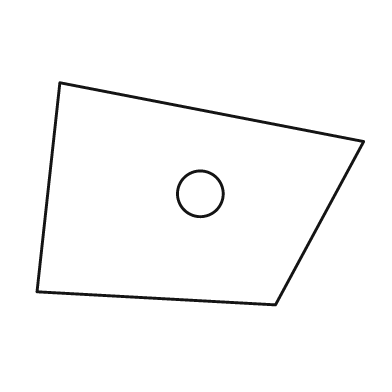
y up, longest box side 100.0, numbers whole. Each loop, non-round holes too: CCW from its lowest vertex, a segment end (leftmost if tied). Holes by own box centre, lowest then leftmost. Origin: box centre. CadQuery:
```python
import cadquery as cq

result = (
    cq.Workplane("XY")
    .moveTo(23.0, -34.0)
    .lineTo(50.0, 16.0)
    .lineTo(-43.0, 34.0)
    .lineTo(-50.0, -30.0)
    .close()
    .moveTo(0.0, 0.0)
    .circle(7.0)
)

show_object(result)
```